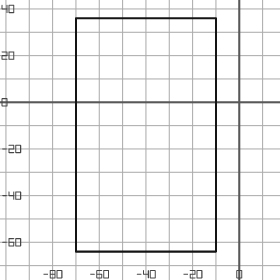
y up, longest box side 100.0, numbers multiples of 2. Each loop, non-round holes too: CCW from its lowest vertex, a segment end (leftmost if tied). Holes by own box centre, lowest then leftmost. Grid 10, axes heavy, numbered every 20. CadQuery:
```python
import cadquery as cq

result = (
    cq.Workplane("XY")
    .moveTo(-70.0, -64.0)
    .lineTo(-10.0, -64.0)
    .lineTo(-10.0, 36.0)
    .lineTo(-70.0, 36.0)
    .close()
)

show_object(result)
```